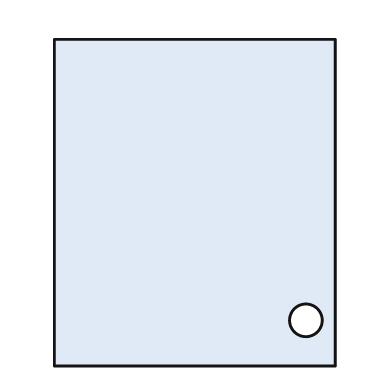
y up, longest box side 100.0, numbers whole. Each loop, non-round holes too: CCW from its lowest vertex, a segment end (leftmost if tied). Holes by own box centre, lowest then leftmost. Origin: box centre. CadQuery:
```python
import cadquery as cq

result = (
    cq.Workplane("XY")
    .moveTo(-43.0, -50.0)
    .lineTo(43.0, -50.0)
    .lineTo(43.0, 50.0)
    .lineTo(-43.0, 50.0)
    .close()
    .moveTo(34.0, -36.0)
    .circle(5.0)
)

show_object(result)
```